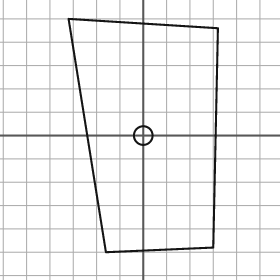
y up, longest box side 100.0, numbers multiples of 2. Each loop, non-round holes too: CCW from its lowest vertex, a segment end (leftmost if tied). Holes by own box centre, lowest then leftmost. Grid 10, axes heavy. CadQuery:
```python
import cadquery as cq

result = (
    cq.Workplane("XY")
    .moveTo(-16.0, -50.0)
    .lineTo(30.0, -48.0)
    .lineTo(32.0, 46.0)
    .lineTo(-32.0, 50.0)
    .close()
    .moveTo(0.0, 0.0)
    .circle(4.0)
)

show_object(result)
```